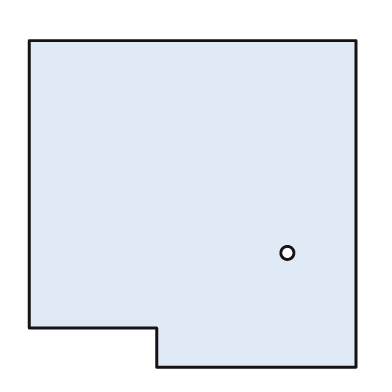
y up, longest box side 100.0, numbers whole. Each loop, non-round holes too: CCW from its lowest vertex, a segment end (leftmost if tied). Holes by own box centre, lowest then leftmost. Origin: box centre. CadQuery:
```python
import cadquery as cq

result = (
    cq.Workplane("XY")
    .moveTo(-11.0, -50.0)
    .lineTo(50.0, -50.0)
    .lineTo(50.0, 50.0)
    .lineTo(-50.0, 50.0)
    .lineTo(-50.0, -38.0)
    .lineTo(-11.0, -38.0)
    .close()
    .moveTo(29.0, -15.0)
    .circle(2.0)
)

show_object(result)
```